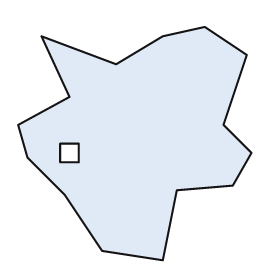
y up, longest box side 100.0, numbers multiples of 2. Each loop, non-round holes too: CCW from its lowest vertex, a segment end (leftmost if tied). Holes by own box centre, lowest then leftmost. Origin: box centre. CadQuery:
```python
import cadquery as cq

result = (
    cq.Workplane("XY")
    .moveTo(12.0, -50.0)
    .lineTo(18.0, -20.0)
    .lineTo(42.0, -18.0)
    .lineTo(50.0, -4.0)
    .lineTo(38.0, 8.0)
    .lineTo(48.0, 38.0)
    .lineTo(30.0, 50.0)
    .lineTo(12.0, 46.0)
    .lineTo(-8.0, 34.0)
    .lineTo(-40.0, 46.0)
    .lineTo(-28.0, 20.0)
    .lineTo(-50.0, 8.0)
    .lineTo(-46.0, -6.0)
    .lineTo(-30.0, -22.0)
    .lineTo(-14.0, -46.0)
    .close()
    .moveTo(-32.0, -8.0)
    .lineTo(-24.0, -8.0)
    .lineTo(-24.0, 0.0)
    .lineTo(-32.0, 0.0)
    .close()
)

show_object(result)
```